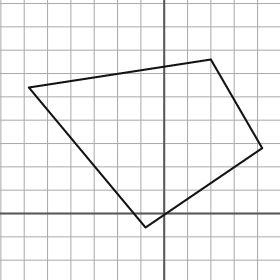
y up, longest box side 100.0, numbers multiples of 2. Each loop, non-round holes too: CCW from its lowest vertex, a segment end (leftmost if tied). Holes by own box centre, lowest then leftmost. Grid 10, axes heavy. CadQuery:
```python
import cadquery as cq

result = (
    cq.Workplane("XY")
    .moveTo(-8.0, -6.0)
    .lineTo(42.0, 28.0)
    .lineTo(20.0, 66.0)
    .lineTo(-58.0, 54.0)
    .close()
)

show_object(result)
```